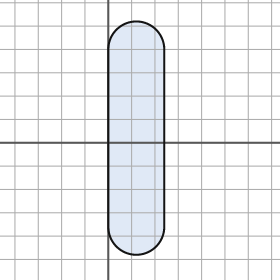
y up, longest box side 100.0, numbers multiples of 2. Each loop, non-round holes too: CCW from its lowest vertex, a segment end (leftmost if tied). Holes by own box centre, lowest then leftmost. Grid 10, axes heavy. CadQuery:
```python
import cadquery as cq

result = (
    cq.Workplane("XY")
    .moveTo(0.0, -36.0)
    .threePointArc((12.0, -48.0), (24.0, -36.0))
    .lineTo(24.0, 40.0)
    .threePointArc((12.0, 52.0), (0.0, 40.0))
    .close()
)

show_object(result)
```